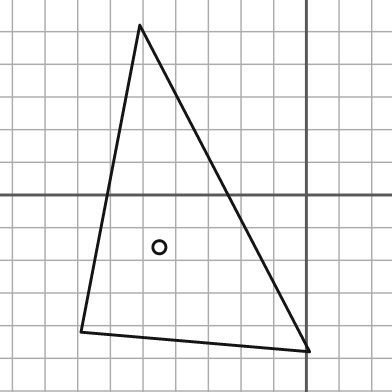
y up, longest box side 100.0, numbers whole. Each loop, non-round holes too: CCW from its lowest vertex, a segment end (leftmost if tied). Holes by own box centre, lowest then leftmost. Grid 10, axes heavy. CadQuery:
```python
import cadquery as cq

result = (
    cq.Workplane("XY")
    .moveTo(1.0, -48.0)
    .lineTo(-51.0, 52.0)
    .lineTo(-69.0, -42.0)
    .close()
    .moveTo(-45.0, -16.0)
    .circle(2.0)
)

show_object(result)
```